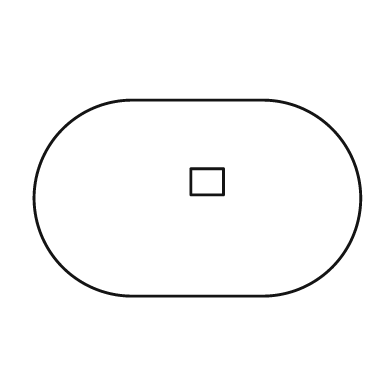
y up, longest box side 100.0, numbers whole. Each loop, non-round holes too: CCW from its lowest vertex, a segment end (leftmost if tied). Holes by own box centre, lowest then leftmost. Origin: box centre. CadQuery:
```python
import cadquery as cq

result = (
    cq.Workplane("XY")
    .moveTo(-20.0, -30.0)
    .lineTo(20.0, -30.0)
    .threePointArc((50.0, 0.0), (20.0, 30.0))
    .lineTo(-20.0, 30.0)
    .threePointArc((-50.0, 0.0), (-20.0, -30.0))
    .close()
    .moveTo(-2.0, 1.0)
    .lineTo(8.0, 1.0)
    .lineTo(8.0, 9.0)
    .lineTo(-2.0, 9.0)
    .close()
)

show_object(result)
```